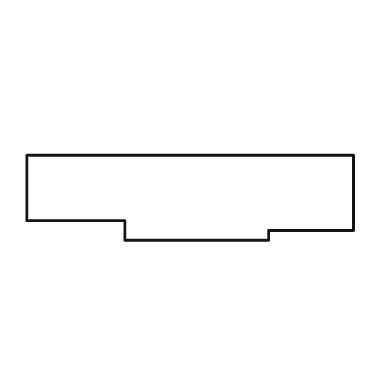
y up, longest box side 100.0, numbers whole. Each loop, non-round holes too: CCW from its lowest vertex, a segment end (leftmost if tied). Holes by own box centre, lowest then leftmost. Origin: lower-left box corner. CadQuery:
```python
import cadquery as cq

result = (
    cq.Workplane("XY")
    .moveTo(30.0, 0.0)
    .lineTo(74.0, 0.0)
    .lineTo(74.0, 3.0)
    .lineTo(100.0, 3.0)
    .lineTo(100.0, 26.0)
    .lineTo(0.0, 26.0)
    .lineTo(0.0, 6.0)
    .lineTo(30.0, 6.0)
    .close()
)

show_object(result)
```